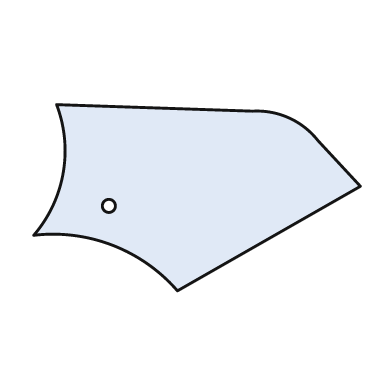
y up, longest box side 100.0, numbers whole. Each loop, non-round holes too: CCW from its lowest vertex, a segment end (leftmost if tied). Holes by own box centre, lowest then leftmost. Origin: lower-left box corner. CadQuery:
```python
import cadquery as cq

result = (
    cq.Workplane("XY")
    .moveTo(44.0, 0.0)
    .lineTo(100.0, 32.0)
    .lineTo(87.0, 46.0)
    .threePointArc((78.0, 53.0), (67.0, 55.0))
    .lineTo(7.0, 57.0)
    .threePointArc((9.0, 36.0), (0.0, 17.0))
    .threePointArc((24.0, 14.0), (44.0, 0.0))
    .close()
    .moveTo(23.0, 26.0)
    .circle(2.0)
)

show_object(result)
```